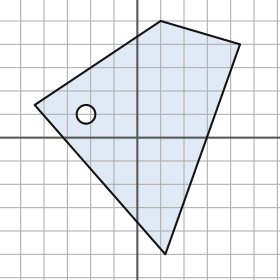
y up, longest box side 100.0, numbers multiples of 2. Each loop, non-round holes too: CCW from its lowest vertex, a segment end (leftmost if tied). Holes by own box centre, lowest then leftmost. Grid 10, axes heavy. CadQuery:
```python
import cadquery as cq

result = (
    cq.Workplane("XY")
    .moveTo(12.0, -50.0)
    .lineTo(44.0, 40.0)
    .lineTo(10.0, 50.0)
    .lineTo(-44.0, 14.0)
    .close()
    .moveTo(-22.0, 10.0)
    .circle(4.0)
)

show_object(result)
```